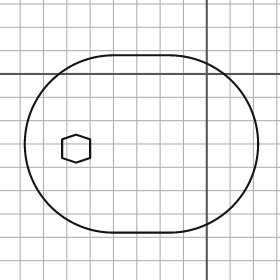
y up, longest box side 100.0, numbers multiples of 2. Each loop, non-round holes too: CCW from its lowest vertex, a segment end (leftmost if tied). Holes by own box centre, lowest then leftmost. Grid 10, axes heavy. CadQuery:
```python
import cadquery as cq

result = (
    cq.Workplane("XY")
    .moveTo(-40.0, -68.0)
    .lineTo(-16.0, -68.0)
    .threePointArc((22.0, -30.0), (-16.0, 8.0))
    .lineTo(-40.0, 8.0)
    .threePointArc((-78.0, -30.0), (-40.0, -68.0))
    .close()
    .moveTo(-56.0, -38.0)
    .lineTo(-50.0, -36.0)
    .lineTo(-50.0, -28.0)
    .lineTo(-56.0, -26.0)
    .lineTo(-62.0, -28.0)
    .lineTo(-62.0, -36.0)
    .close()
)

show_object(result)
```